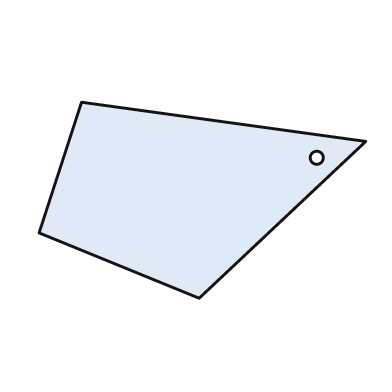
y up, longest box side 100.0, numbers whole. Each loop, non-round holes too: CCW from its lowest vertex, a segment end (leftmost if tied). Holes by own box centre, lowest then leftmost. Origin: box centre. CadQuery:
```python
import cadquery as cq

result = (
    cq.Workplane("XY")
    .moveTo(-1.0, -30.0)
    .lineTo(50.0, 18.0)
    .lineTo(-37.0, 30.0)
    .lineTo(-50.0, -10.0)
    .close()
    .moveTo(35.0, 13.0)
    .circle(2.0)
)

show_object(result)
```